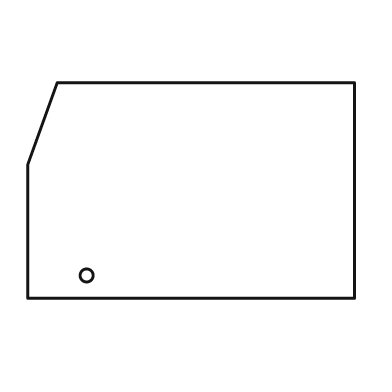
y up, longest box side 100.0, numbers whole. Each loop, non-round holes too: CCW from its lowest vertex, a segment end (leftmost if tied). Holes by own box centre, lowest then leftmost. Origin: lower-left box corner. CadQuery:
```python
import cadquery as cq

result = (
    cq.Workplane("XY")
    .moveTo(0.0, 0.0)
    .lineTo(100.0, 0.0)
    .lineTo(100.0, 66.0)
    .lineTo(9.0, 66.0)
    .lineTo(0.0, 41.0)
    .close()
    .moveTo(18.0, 7.0)
    .circle(2.0)
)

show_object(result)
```